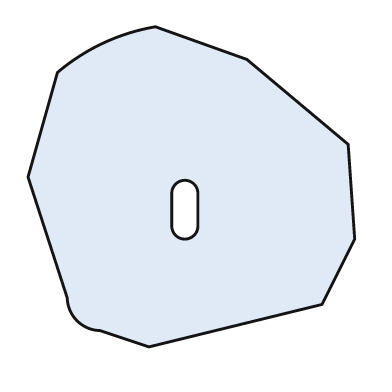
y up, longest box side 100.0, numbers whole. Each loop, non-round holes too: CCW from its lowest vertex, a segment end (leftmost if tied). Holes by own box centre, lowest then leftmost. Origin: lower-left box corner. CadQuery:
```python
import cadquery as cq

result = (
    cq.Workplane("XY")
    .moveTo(37.0, 0.0)
    .lineTo(90.0, 13.0)
    .lineTo(100.0, 33.0)
    .lineTo(98.0, 62.0)
    .lineTo(67.0, 88.0)
    .lineTo(39.0, 98.0)
    .threePointArc((23.0, 93.0), (9.0, 84.0))
    .lineTo(0.0, 52.0)
    .lineTo(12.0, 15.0)
    .threePointArc((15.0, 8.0), (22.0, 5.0))
    .close()
    .moveTo(44.0, 37.0)
    .threePointArc((48.0, 33.0), (52.0, 37.0))
    .lineTo(52.0, 47.0)
    .threePointArc((48.0, 51.0), (44.0, 47.0))
    .close()
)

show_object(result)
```